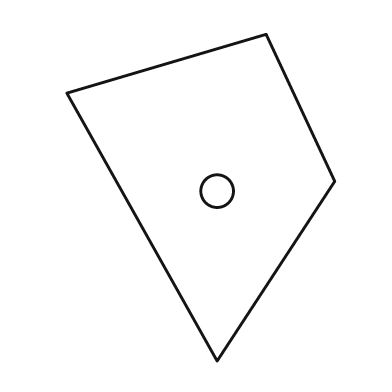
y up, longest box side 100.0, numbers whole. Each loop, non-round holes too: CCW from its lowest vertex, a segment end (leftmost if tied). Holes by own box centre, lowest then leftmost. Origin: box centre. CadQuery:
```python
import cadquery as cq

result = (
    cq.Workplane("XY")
    .moveTo(5.0, -50.0)
    .lineTo(41.0, 5.0)
    .lineTo(20.0, 50.0)
    .lineTo(-41.0, 32.0)
    .close()
    .moveTo(5.0, 2.0)
    .circle(5.0)
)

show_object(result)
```